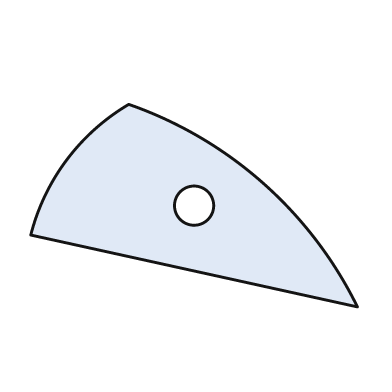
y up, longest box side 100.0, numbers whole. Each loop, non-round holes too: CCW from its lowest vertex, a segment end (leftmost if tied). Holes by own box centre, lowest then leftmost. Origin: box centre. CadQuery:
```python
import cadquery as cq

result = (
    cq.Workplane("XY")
    .moveTo(50.0, -31.0)
    .threePointArc((21.0, 7.0), (-20.0, 31.0))
    .threePointArc((-39.0, 14.0), (-50.0, -9.0))
    .close()
    .moveTo(0.0, 0.0)
    .circle(6.0)
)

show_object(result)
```